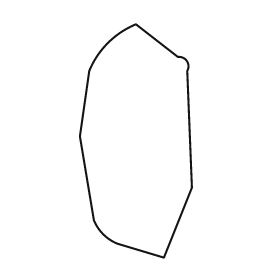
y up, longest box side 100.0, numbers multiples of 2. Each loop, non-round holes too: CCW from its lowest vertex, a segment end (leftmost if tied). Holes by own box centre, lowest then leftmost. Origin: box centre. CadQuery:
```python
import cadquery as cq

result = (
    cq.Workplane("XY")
    .moveTo(12.0, -50.0)
    .lineTo(24.0, -20.0)
    .lineTo(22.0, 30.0)
    .threePointArc((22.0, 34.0), (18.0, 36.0))
    .lineTo(0.0, 50.0)
    .threePointArc((-12.0, 42.0), (-20.0, 30.0))
    .lineTo(-24.0, 2.0)
    .lineTo(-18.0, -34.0)
    .threePointArc((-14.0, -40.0), (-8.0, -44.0))
    .close()
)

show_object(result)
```